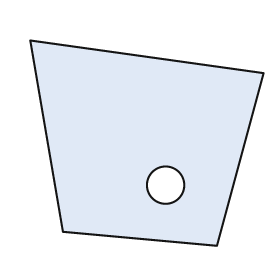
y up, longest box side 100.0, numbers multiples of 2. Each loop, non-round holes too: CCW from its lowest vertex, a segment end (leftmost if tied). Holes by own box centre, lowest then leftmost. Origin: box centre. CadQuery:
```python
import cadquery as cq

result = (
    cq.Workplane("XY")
    .moveTo(30.0, -44.0)
    .lineTo(50.0, 30.0)
    .lineTo(-50.0, 44.0)
    .lineTo(-36.0, -38.0)
    .close()
    .moveTo(8.0, -18.0)
    .circle(8.0)
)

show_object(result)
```